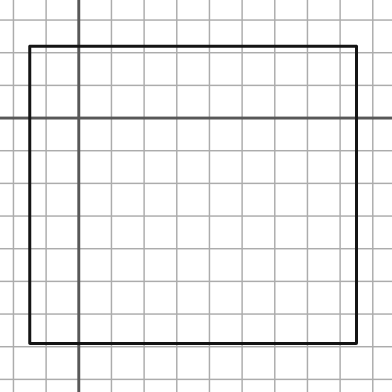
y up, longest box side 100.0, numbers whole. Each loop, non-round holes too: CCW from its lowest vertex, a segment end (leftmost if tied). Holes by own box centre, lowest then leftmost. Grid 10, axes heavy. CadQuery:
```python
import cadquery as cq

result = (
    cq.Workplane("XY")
    .moveTo(-15.0, -69.0)
    .lineTo(85.0, -69.0)
    .lineTo(85.0, 22.0)
    .lineTo(-15.0, 22.0)
    .close()
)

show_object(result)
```